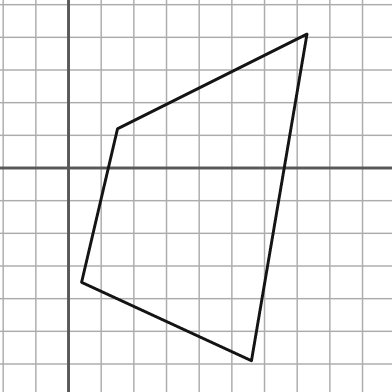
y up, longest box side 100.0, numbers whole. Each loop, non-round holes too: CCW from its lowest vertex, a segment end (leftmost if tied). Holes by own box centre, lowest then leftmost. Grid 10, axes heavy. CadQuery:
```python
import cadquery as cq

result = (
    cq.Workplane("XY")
    .moveTo(56.0, -59.0)
    .lineTo(73.0, 41.0)
    .lineTo(15.0, 12.0)
    .lineTo(4.0, -35.0)
    .close()
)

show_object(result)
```